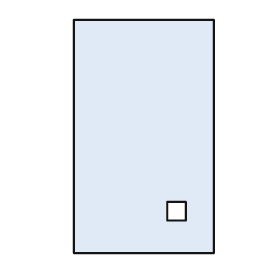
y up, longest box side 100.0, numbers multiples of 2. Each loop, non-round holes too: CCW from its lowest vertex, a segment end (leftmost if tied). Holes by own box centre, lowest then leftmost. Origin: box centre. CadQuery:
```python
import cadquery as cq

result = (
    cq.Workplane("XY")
    .moveTo(-30.0, -50.0)
    .lineTo(30.0, -50.0)
    .lineTo(30.0, 50.0)
    .lineTo(-30.0, 50.0)
    .close()
    .moveTo(10.0, -36.0)
    .lineTo(18.0, -36.0)
    .lineTo(18.0, -28.0)
    .lineTo(10.0, -28.0)
    .close()
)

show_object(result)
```